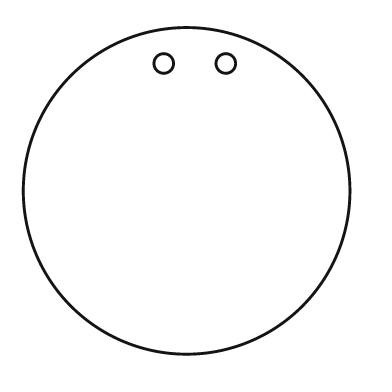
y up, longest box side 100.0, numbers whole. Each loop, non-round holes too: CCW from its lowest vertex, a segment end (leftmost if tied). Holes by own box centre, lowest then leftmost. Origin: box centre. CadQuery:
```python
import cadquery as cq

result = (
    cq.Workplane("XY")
    .moveTo(0.0, 0.0)
    .circle(50.0)
    .moveTo(-7.0, 39.0)
    .circle(3.0)
    .moveTo(12.0, 39.0)
    .circle(3.0)
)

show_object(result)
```